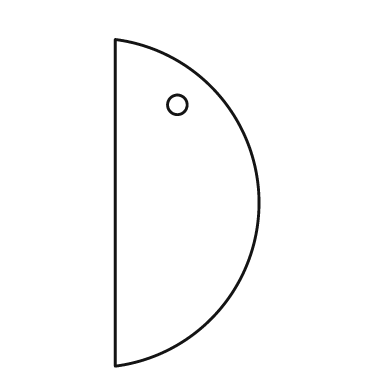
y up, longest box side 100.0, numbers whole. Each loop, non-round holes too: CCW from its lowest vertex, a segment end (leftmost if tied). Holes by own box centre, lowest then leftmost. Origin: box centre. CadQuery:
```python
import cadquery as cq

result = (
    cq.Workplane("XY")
    .moveTo(-22.0, -50.0)
    .threePointArc((22.0, 0.0), (-22.0, 50.0))
    .close()
    .moveTo(-3.0, 30.0)
    .circle(3.0)
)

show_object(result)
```